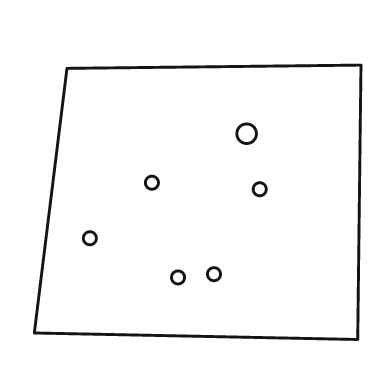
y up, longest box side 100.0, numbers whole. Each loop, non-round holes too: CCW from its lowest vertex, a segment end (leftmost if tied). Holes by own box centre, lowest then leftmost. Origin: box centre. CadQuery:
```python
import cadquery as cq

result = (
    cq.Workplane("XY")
    .moveTo(49.0, -42.0)
    .lineTo(50.0, 42.0)
    .lineTo(-40.0, 41.0)
    .lineTo(-50.0, -40.0)
    .close()
    .moveTo(-6.0, -23.0)
    .circle(2.0)
    .moveTo(5.0, -22.0)
    .circle(2.0)
    .moveTo(-33.0, -11.0)
    .circle(2.0)
    .moveTo(19.0, 4.0)
    .circle(2.0)
    .moveTo(-14.0, 6.0)
    .circle(2.0)
    .moveTo(15.0, 21.0)
    .circle(3.0)
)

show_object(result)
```